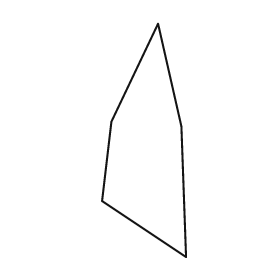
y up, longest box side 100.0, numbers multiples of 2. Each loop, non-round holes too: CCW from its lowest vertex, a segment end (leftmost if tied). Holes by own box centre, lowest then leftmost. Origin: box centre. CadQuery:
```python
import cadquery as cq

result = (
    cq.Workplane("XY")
    .moveTo(18.0, -50.0)
    .lineTo(16.0, 6.0)
    .lineTo(6.0, 50.0)
    .lineTo(-14.0, 8.0)
    .lineTo(-18.0, -26.0)
    .close()
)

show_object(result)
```